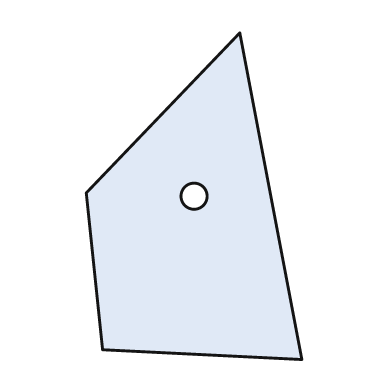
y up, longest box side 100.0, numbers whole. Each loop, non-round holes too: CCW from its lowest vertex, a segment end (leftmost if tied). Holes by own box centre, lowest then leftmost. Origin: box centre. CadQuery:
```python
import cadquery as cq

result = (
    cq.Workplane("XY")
    .moveTo(33.0, -50.0)
    .lineTo(14.0, 50.0)
    .lineTo(-33.0, 1.0)
    .lineTo(-28.0, -47.0)
    .close()
    .moveTo(0.0, 0.0)
    .circle(4.0)
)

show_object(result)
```